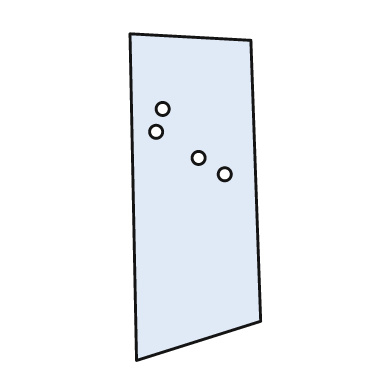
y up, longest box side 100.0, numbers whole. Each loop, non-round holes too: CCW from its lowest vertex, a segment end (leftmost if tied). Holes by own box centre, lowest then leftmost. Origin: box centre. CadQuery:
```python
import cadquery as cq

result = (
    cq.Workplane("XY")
    .moveTo(-18.0, -50.0)
    .lineTo(20.0, -38.0)
    .lineTo(17.0, 48.0)
    .lineTo(-20.0, 50.0)
    .close()
    .moveTo(9.0, 7.0)
    .circle(2.0)
    .moveTo(1.0, 12.0)
    .circle(2.0)
    .moveTo(-12.0, 20.0)
    .circle(2.0)
    .moveTo(-10.0, 27.0)
    .circle(2.0)
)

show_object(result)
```